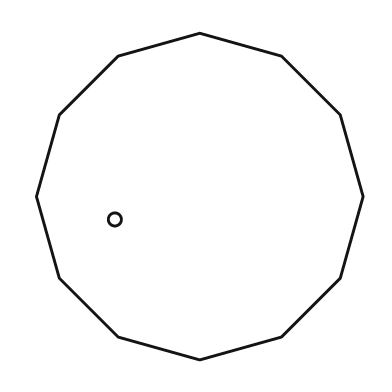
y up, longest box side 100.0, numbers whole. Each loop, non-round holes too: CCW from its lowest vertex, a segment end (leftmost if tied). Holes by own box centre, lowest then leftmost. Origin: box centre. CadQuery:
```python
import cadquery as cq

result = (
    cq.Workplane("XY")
    .moveTo(0.0, -50.0)
    .lineTo(25.0, -43.0)
    .lineTo(43.0, -25.0)
    .lineTo(50.0, 0.0)
    .lineTo(43.0, 25.0)
    .lineTo(25.0, 43.0)
    .lineTo(0.0, 50.0)
    .lineTo(-25.0, 43.0)
    .lineTo(-43.0, 25.0)
    .lineTo(-50.0, 0.0)
    .lineTo(-43.0, -25.0)
    .lineTo(-25.0, -43.0)
    .close()
    .moveTo(-26.0, -7.0)
    .circle(2.0)
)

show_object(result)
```